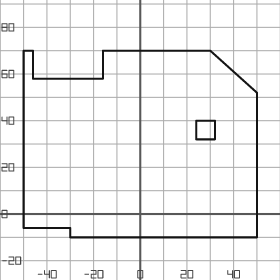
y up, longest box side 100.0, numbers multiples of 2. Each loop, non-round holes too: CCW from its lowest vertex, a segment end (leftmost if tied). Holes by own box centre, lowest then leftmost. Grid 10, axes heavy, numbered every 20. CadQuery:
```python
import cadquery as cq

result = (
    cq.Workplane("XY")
    .moveTo(-30.0, -10.0)
    .lineTo(50.0, -10.0)
    .lineTo(50.0, 52.0)
    .lineTo(30.0, 70.0)
    .lineTo(-16.0, 70.0)
    .lineTo(-16.0, 58.0)
    .lineTo(-46.0, 58.0)
    .lineTo(-46.0, 70.0)
    .lineTo(-50.0, 70.0)
    .lineTo(-50.0, -6.0)
    .lineTo(-30.0, -6.0)
    .close()
    .moveTo(24.0, 32.0)
    .lineTo(32.0, 32.0)
    .lineTo(32.0, 40.0)
    .lineTo(24.0, 40.0)
    .close()
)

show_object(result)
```